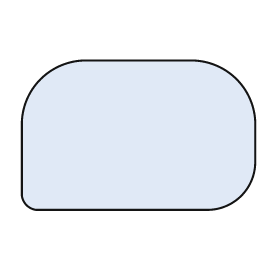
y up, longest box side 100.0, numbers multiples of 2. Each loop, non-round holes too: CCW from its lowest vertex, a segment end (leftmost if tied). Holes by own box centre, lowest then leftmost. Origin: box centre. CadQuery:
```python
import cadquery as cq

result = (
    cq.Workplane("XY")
    .moveTo(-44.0, -32.0)
    .lineTo(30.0, -32.0)
    .threePointArc((44.0, -26.0), (50.0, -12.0))
    .lineTo(50.0, 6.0)
    .threePointArc((42.0, 24.0), (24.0, 32.0))
    .lineTo(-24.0, 32.0)
    .threePointArc((-42.0, 24.0), (-50.0, 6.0))
    .lineTo(-50.0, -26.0)
    .threePointArc((-48.0, -30.0), (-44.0, -32.0))
    .close()
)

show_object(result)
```